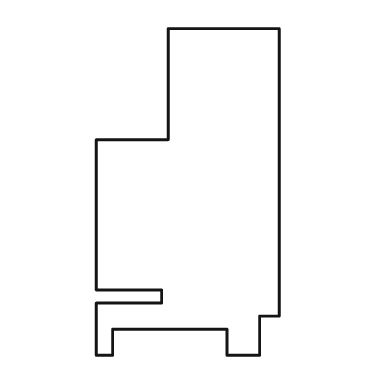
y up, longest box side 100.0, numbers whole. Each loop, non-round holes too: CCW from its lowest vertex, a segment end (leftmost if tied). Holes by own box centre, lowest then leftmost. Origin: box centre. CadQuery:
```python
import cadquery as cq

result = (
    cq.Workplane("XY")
    .moveTo(-28.0, -50.0)
    .lineTo(-23.0, -50.0)
    .lineTo(-23.0, -42.0)
    .lineTo(12.0, -42.0)
    .lineTo(12.0, -50.0)
    .lineTo(22.0, -50.0)
    .lineTo(22.0, -38.0)
    .lineTo(28.0, -38.0)
    .lineTo(28.0, 50.0)
    .lineTo(-6.0, 50.0)
    .lineTo(-6.0, 16.0)
    .lineTo(-28.0, 16.0)
    .lineTo(-28.0, -30.0)
    .lineTo(-8.0, -30.0)
    .lineTo(-8.0, -34.0)
    .lineTo(-28.0, -34.0)
    .close()
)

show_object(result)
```